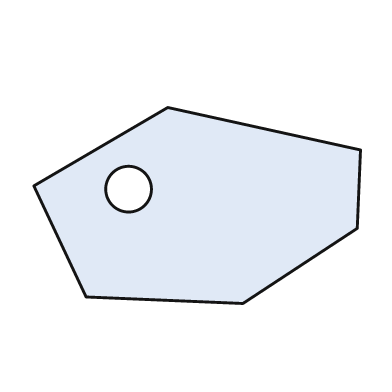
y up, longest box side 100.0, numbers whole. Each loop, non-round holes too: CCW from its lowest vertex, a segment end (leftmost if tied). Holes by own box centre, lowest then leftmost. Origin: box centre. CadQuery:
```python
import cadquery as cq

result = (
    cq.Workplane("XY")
    .moveTo(14.0, -30.0)
    .lineTo(49.0, -7.0)
    .lineTo(50.0, 17.0)
    .lineTo(-9.0, 30.0)
    .lineTo(-50.0, 6.0)
    .lineTo(-34.0, -28.0)
    .close()
    .moveTo(-21.0, 5.0)
    .circle(7.0)
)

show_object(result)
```